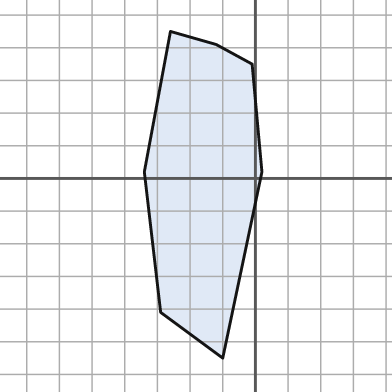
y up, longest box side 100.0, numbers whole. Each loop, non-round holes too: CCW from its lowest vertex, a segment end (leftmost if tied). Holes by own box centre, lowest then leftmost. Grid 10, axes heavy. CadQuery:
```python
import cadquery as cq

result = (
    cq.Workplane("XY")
    .moveTo(-10.0, -55.0)
    .lineTo(2.0, 2.0)
    .lineTo(-1.0, 35.0)
    .lineTo(-12.0, 41.0)
    .lineTo(-26.0, 45.0)
    .lineTo(-34.0, 2.0)
    .lineTo(-29.0, -41.0)
    .close()
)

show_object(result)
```